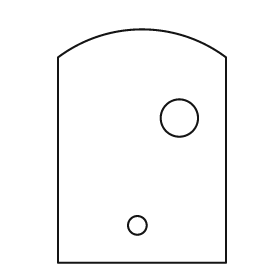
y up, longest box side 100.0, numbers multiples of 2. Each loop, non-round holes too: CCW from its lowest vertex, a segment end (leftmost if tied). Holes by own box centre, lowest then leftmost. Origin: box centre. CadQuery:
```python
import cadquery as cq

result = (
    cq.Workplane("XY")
    .moveTo(-36.0, -50.0)
    .lineTo(36.0, -50.0)
    .lineTo(36.0, 38.0)
    .threePointArc((0.0, 50.0), (-36.0, 38.0))
    .close()
    .moveTo(-2.0, -34.0)
    .circle(4.0)
    .moveTo(16.0, 12.0)
    .circle(8.0)
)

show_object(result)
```